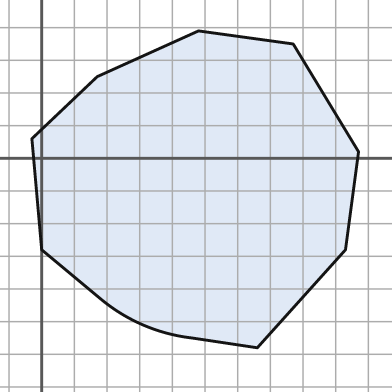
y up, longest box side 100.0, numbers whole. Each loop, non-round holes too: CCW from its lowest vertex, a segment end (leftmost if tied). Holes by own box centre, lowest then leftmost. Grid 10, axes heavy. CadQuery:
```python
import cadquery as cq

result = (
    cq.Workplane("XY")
    .moveTo(66.0, -58.0)
    .lineTo(93.0, -28.0)
    .lineTo(97.0, 2.0)
    .lineTo(77.0, 35.0)
    .lineTo(48.0, 39.0)
    .lineTo(17.0, 25.0)
    .lineTo(-3.0, 6.0)
    .lineTo(0.0, -28.0)
    .lineTo(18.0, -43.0)
    .threePointArc((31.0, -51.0), (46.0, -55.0))
    .close()
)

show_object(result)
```